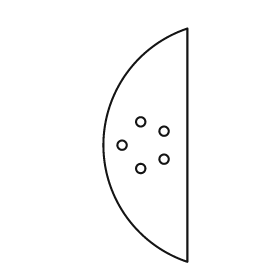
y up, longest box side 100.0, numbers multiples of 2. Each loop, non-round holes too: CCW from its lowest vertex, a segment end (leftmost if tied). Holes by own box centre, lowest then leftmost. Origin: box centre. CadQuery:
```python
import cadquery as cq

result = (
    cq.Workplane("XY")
    .moveTo(18.0, -50.0)
    .lineTo(18.0, 50.0)
    .threePointArc((-18.0, 0.0), (18.0, -50.0))
    .close()
    .moveTo(-2.0, -10.0)
    .circle(2.0)
    .moveTo(8.0, -6.0)
    .circle(2.0)
    .moveTo(-10.0, 0.0)
    .circle(2.0)
    .moveTo(8.0, 6.0)
    .circle(2.0)
    .moveTo(-2.0, 10.0)
    .circle(2.0)
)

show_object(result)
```